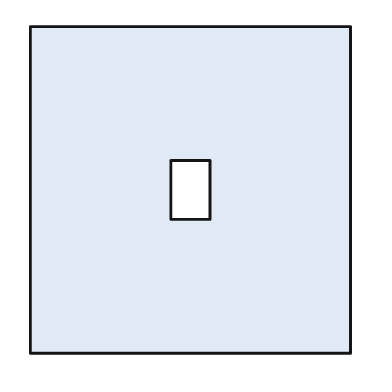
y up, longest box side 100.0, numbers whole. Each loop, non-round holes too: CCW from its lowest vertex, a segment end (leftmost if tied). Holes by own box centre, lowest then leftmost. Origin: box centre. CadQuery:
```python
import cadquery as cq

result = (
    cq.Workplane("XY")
    .moveTo(-49.0, -50.0)
    .lineTo(49.0, -50.0)
    .lineTo(49.0, 50.0)
    .lineTo(-49.0, 50.0)
    .close()
    .moveTo(-6.0, -9.0)
    .lineTo(6.0, -9.0)
    .lineTo(6.0, 9.0)
    .lineTo(-6.0, 9.0)
    .close()
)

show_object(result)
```